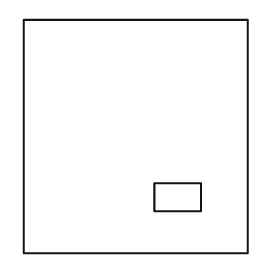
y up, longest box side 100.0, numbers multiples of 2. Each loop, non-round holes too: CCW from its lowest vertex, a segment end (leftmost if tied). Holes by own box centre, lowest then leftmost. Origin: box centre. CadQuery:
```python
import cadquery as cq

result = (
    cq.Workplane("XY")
    .moveTo(-48.0, -50.0)
    .lineTo(48.0, -50.0)
    .lineTo(48.0, 50.0)
    .lineTo(-48.0, 50.0)
    .close()
    .moveTo(8.0, -32.0)
    .lineTo(28.0, -32.0)
    .lineTo(28.0, -20.0)
    .lineTo(8.0, -20.0)
    .close()
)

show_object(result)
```